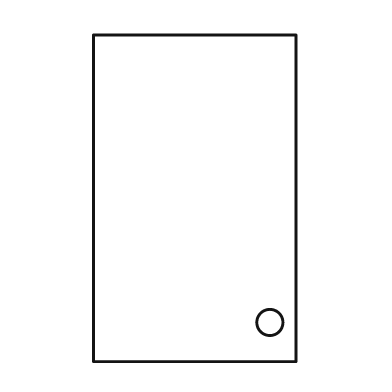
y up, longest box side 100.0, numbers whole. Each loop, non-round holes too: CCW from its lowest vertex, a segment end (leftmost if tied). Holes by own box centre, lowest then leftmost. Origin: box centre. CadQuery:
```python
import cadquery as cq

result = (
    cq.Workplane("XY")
    .moveTo(-31.0, -50.0)
    .lineTo(31.0, -50.0)
    .lineTo(31.0, 50.0)
    .lineTo(-31.0, 50.0)
    .close()
    .moveTo(23.0, -38.0)
    .circle(4.0)
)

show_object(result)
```